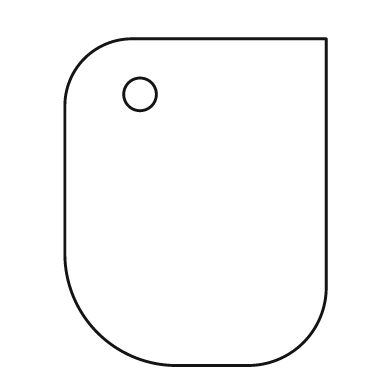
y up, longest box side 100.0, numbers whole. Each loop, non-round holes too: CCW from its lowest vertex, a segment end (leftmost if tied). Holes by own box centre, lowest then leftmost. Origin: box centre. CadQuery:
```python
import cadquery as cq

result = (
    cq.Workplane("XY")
    .moveTo(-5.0, -50.0)
    .lineTo(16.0, -50.0)
    .threePointArc((33.0, -43.0), (40.0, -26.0))
    .lineTo(40.0, 50.0)
    .lineTo(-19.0, 50.0)
    .threePointArc((-34.0, 44.0), (-40.0, 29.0))
    .lineTo(-40.0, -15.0)
    .threePointArc((-30.0, -40.0), (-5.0, -50.0))
    .close()
    .moveTo(-17.0, 33.0)
    .circle(5.0)
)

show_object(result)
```